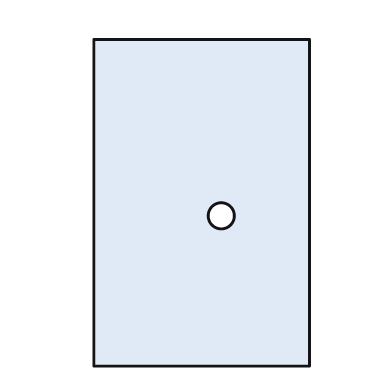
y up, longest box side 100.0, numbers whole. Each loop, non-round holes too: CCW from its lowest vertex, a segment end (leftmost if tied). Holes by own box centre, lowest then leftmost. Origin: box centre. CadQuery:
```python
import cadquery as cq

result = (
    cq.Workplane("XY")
    .moveTo(-33.0, -50.0)
    .lineTo(33.0, -50.0)
    .lineTo(33.0, 50.0)
    .lineTo(-33.0, 50.0)
    .close()
    .moveTo(6.0, -4.0)
    .circle(4.0)
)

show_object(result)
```